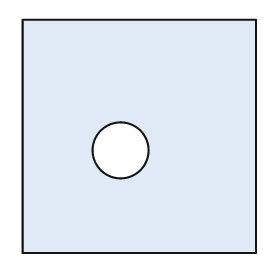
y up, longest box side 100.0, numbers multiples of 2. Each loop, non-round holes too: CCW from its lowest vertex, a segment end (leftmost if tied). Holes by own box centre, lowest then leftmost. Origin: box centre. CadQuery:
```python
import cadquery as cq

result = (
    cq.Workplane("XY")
    .moveTo(-50.0, -50.0)
    .lineTo(50.0, -50.0)
    .lineTo(50.0, 50.0)
    .lineTo(-50.0, 50.0)
    .close()
    .moveTo(-8.0, -6.0)
    .circle(12.0)
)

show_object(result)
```